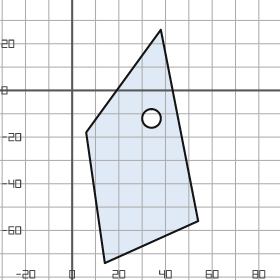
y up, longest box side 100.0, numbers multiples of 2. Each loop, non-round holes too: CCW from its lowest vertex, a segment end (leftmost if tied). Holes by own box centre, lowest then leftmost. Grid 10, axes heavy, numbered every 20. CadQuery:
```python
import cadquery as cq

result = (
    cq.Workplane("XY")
    .moveTo(14.0, -74.0)
    .lineTo(54.0, -56.0)
    .lineTo(38.0, 26.0)
    .lineTo(6.0, -18.0)
    .close()
    .moveTo(34.0, -12.0)
    .circle(4.0)
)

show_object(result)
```